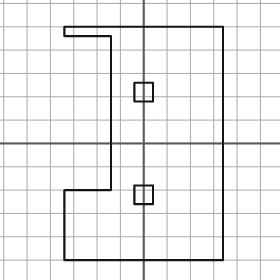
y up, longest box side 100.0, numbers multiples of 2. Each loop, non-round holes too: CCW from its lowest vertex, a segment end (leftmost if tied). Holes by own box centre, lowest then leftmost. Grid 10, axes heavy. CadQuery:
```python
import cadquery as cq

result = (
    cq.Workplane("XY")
    .moveTo(-34.0, -50.0)
    .lineTo(34.0, -50.0)
    .lineTo(34.0, 50.0)
    .lineTo(-34.0, 50.0)
    .lineTo(-34.0, 46.0)
    .lineTo(-14.0, 46.0)
    .lineTo(-14.0, -20.0)
    .lineTo(-34.0, -20.0)
    .close()
    .moveTo(-4.0, -26.0)
    .lineTo(4.0, -26.0)
    .lineTo(4.0, -18.0)
    .lineTo(-4.0, -18.0)
    .close()
    .moveTo(-4.0, 18.0)
    .lineTo(4.0, 18.0)
    .lineTo(4.0, 26.0)
    .lineTo(-4.0, 26.0)
    .close()
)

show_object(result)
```